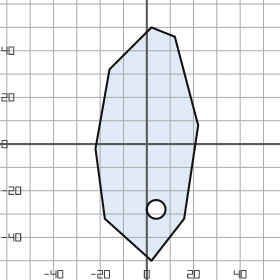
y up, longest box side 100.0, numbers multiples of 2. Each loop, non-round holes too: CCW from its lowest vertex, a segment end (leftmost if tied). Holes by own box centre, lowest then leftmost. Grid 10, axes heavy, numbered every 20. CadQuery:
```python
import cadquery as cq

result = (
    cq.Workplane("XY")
    .moveTo(2.0, -50.0)
    .lineTo(16.0, -32.0)
    .lineTo(22.0, 8.0)
    .lineTo(12.0, 46.0)
    .lineTo(2.0, 50.0)
    .lineTo(-16.0, 32.0)
    .lineTo(-22.0, -2.0)
    .lineTo(-18.0, -32.0)
    .close()
    .moveTo(4.0, -28.0)
    .circle(4.0)
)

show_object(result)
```